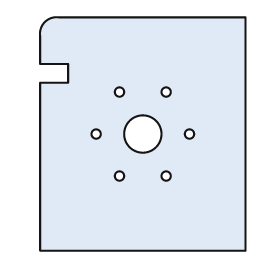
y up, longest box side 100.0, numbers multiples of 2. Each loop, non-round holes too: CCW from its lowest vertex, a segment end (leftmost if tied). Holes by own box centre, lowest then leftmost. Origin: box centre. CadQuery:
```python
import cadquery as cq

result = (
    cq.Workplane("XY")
    .moveTo(-44.0, -50.0)
    .lineTo(44.0, -50.0)
    .lineTo(44.0, 50.0)
    .lineTo(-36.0, 50.0)
    .threePointArc((-42.0, 48.0), (-44.0, 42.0))
    .lineTo(-44.0, 30.0)
    .lineTo(-32.0, 30.0)
    .lineTo(-32.0, 22.0)
    .lineTo(-44.0, 22.0)
    .close()
    .moveTo(-10.0, -18.0)
    .circle(2.0)
    .moveTo(10.0, -18.0)
    .circle(2.0)
    .moveTo(-20.0, 0.0)
    .circle(2.0)
    .moveTo(0.0, 0.0)
    .circle(8.0)
    .moveTo(20.0, 0.0)
    .circle(2.0)
    .moveTo(-10.0, 18.0)
    .circle(2.0)
    .moveTo(10.0, 18.0)
    .circle(2.0)
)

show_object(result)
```